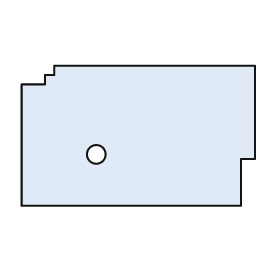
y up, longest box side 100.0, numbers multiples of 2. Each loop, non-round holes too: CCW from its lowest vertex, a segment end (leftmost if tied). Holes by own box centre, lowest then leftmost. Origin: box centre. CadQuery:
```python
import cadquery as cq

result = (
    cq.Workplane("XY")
    .moveTo(-50.0, -30.0)
    .lineTo(44.0, -30.0)
    .lineTo(44.0, -10.0)
    .lineTo(50.0, -10.0)
    .lineTo(50.0, 30.0)
    .lineTo(-36.0, 30.0)
    .lineTo(-36.0, 26.0)
    .lineTo(-40.0, 26.0)
    .lineTo(-40.0, 22.0)
    .lineTo(-50.0, 22.0)
    .close()
    .moveTo(-18.0, -8.0)
    .circle(4.0)
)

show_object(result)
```